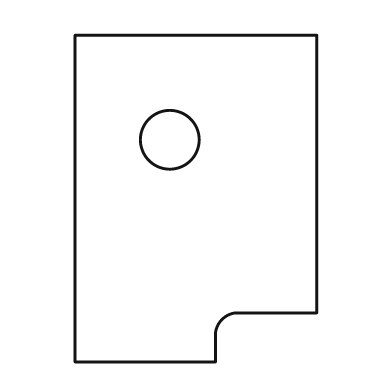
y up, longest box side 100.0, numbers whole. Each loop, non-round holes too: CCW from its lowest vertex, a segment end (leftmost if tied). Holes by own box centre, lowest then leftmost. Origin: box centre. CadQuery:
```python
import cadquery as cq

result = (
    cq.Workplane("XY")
    .moveTo(-37.0, -50.0)
    .lineTo(6.0, -50.0)
    .lineTo(6.0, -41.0)
    .threePointArc((8.0, -37.0), (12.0, -35.0))
    .lineTo(37.0, -35.0)
    .lineTo(37.0, 50.0)
    .lineTo(-37.0, 50.0)
    .close()
    .moveTo(-8.0, 18.0)
    .circle(9.0)
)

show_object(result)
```